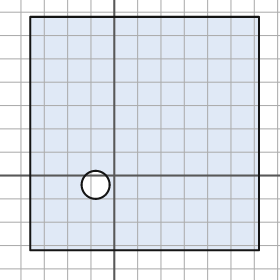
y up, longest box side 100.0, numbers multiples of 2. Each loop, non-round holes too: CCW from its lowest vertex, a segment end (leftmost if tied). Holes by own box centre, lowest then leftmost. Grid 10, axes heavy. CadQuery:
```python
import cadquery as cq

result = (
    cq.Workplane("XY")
    .moveTo(-36.0, -32.0)
    .lineTo(62.0, -32.0)
    .lineTo(62.0, 68.0)
    .lineTo(-36.0, 68.0)
    .close()
    .moveTo(-8.0, -4.0)
    .circle(6.0)
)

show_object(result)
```